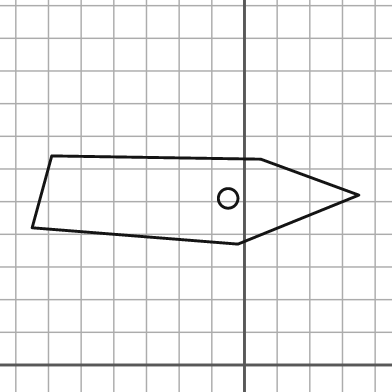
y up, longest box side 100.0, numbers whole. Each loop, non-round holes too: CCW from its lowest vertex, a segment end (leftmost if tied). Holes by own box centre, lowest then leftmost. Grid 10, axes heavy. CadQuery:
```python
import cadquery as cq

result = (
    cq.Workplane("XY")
    .moveTo(-2.0, 37.0)
    .lineTo(35.0, 52.0)
    .lineTo(5.0, 63.0)
    .lineTo(-59.0, 64.0)
    .lineTo(-65.0, 42.0)
    .close()
    .moveTo(-5.0, 51.0)
    .circle(3.0)
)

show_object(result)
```